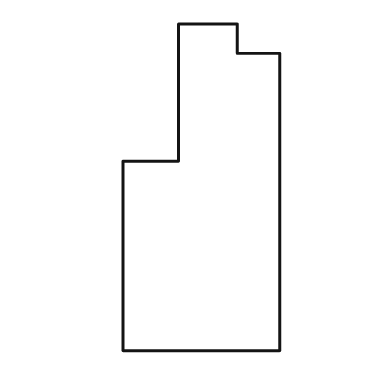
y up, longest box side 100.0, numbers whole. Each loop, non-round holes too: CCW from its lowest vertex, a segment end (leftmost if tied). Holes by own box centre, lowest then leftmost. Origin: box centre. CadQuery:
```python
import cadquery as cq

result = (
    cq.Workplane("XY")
    .moveTo(-24.0, -50.0)
    .lineTo(24.0, -50.0)
    .lineTo(24.0, 41.0)
    .lineTo(11.0, 41.0)
    .lineTo(11.0, 50.0)
    .lineTo(-7.0, 50.0)
    .lineTo(-7.0, 8.0)
    .lineTo(-24.0, 8.0)
    .close()
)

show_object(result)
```